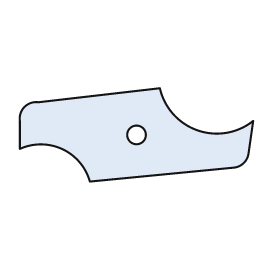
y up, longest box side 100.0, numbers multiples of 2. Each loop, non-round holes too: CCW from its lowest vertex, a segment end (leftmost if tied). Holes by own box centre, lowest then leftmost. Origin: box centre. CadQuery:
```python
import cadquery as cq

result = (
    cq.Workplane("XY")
    .moveTo(-20.0, -20.0)
    .lineTo(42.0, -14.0)
    .threePointArc((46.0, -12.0), (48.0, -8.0))
    .lineTo(50.0, 6.0)
    .threePointArc((26.0, 2.0), (10.0, 20.0))
    .lineTo(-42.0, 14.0)
    .threePointArc((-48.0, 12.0), (-50.0, 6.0))
    .lineTo(-50.0, -6.0)
    .threePointArc((-32.0, -6.0), (-20.0, -20.0))
    .close()
    .moveTo(0.0, 0.0)
    .circle(4.0)
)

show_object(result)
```